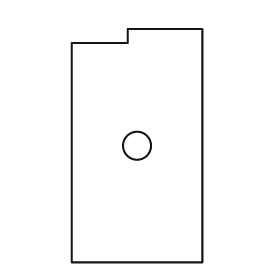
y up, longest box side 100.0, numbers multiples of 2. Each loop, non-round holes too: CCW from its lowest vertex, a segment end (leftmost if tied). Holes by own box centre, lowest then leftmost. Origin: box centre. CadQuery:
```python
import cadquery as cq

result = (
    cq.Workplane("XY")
    .moveTo(-28.0, -50.0)
    .lineTo(28.0, -50.0)
    .lineTo(28.0, 50.0)
    .lineTo(-4.0, 50.0)
    .lineTo(-4.0, 44.0)
    .lineTo(-28.0, 44.0)
    .close()
    .moveTo(0.0, 0.0)
    .circle(6.0)
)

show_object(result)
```